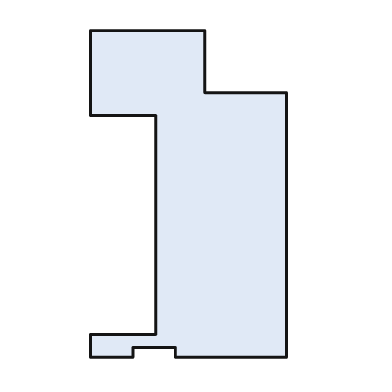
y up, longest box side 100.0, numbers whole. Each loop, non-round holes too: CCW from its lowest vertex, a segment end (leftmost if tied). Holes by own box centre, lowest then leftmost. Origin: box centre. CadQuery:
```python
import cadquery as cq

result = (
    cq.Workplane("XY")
    .moveTo(-30.0, -50.0)
    .lineTo(-17.0, -50.0)
    .lineTo(-17.0, -47.0)
    .lineTo(-4.0, -47.0)
    .lineTo(-4.0, -50.0)
    .lineTo(30.0, -50.0)
    .lineTo(30.0, 31.0)
    .lineTo(5.0, 31.0)
    .lineTo(5.0, 50.0)
    .lineTo(-30.0, 50.0)
    .lineTo(-30.0, 24.0)
    .lineTo(-10.0, 24.0)
    .lineTo(-10.0, -43.0)
    .lineTo(-30.0, -43.0)
    .close()
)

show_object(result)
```